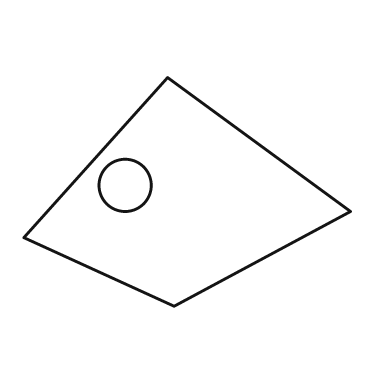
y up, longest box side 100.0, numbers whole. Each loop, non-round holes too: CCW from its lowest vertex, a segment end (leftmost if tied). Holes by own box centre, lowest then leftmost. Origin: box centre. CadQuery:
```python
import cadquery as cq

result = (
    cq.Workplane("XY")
    .moveTo(-4.0, -35.0)
    .lineTo(50.0, -6.0)
    .lineTo(-6.0, 35.0)
    .lineTo(-50.0, -14.0)
    .close()
    .moveTo(-19.0, 2.0)
    .circle(8.0)
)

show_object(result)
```